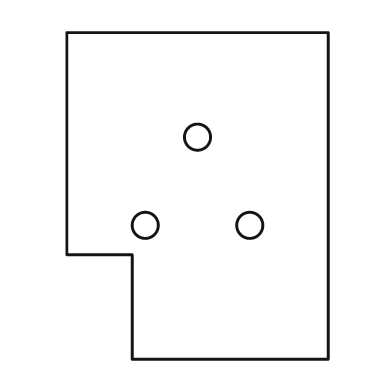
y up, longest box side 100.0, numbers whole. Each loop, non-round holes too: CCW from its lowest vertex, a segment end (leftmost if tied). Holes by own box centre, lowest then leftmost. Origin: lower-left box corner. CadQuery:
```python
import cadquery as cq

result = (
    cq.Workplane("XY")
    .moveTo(20.0, 0.0)
    .lineTo(80.0, 0.0)
    .lineTo(80.0, 100.0)
    .lineTo(0.0, 100.0)
    .lineTo(0.0, 32.0)
    .lineTo(20.0, 32.0)
    .close()
    .moveTo(24.0, 41.0)
    .circle(4.0)
    .moveTo(56.0, 41.0)
    .circle(4.0)
    .moveTo(40.0, 68.0)
    .circle(4.0)
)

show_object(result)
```